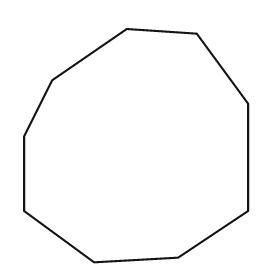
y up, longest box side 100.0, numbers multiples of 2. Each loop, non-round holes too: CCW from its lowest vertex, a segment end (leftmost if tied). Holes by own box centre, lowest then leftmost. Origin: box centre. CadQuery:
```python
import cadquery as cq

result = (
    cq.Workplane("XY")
    .moveTo(-18.0, -50.0)
    .lineTo(18.0, -48.0)
    .lineTo(48.0, -28.0)
    .lineTo(48.0, 18.0)
    .lineTo(26.0, 48.0)
    .lineTo(-4.0, 50.0)
    .lineTo(-36.0, 28.0)
    .lineTo(-48.0, 4.0)
    .lineTo(-48.0, -28.0)
    .close()
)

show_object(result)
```